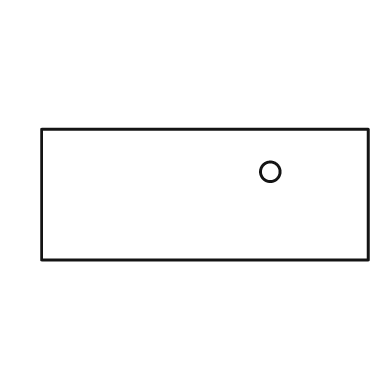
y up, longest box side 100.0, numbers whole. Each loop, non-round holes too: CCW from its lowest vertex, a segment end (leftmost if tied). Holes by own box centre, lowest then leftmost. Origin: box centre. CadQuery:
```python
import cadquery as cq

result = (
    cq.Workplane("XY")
    .moveTo(-50.0, -20.0)
    .lineTo(50.0, -20.0)
    .lineTo(50.0, 20.0)
    .lineTo(-50.0, 20.0)
    .close()
    .moveTo(20.0, 7.0)
    .circle(3.0)
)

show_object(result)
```